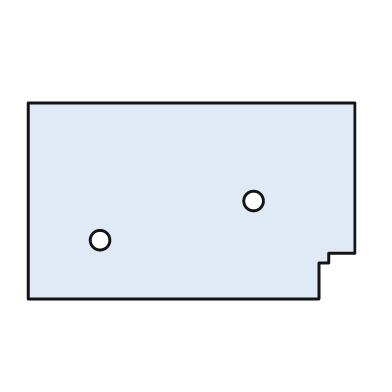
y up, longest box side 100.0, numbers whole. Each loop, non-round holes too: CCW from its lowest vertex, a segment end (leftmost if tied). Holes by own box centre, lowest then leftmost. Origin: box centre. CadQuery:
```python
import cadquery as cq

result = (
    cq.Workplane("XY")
    .moveTo(-50.0, -30.0)
    .lineTo(39.0, -30.0)
    .lineTo(39.0, -19.0)
    .lineTo(42.0, -19.0)
    .lineTo(42.0, -16.0)
    .lineTo(50.0, -16.0)
    .lineTo(50.0, 30.0)
    .lineTo(-50.0, 30.0)
    .close()
    .moveTo(-28.0, -12.0)
    .circle(3.0)
    .moveTo(19.0, 0.0)
    .circle(3.0)
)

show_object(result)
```